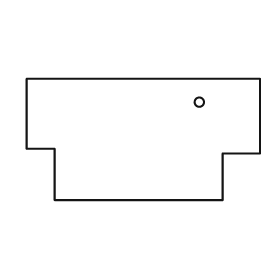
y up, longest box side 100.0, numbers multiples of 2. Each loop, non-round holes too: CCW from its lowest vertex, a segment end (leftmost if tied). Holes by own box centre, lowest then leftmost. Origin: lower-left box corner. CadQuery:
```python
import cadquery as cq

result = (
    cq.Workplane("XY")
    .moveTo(12.0, 0.0)
    .lineTo(84.0, 0.0)
    .lineTo(84.0, 20.0)
    .lineTo(100.0, 20.0)
    .lineTo(100.0, 52.0)
    .lineTo(0.0, 52.0)
    .lineTo(0.0, 22.0)
    .lineTo(12.0, 22.0)
    .close()
    .moveTo(74.0, 42.0)
    .circle(2.0)
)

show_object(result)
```